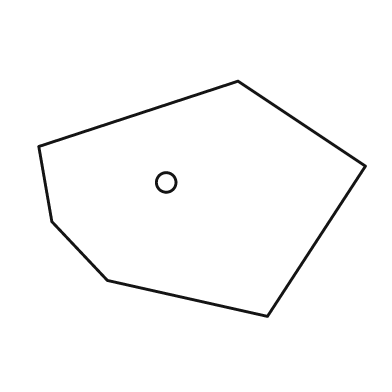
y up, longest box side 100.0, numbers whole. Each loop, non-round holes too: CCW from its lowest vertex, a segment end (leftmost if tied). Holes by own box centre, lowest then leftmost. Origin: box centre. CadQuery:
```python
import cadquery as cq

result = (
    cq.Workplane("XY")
    .moveTo(20.0, -36.0)
    .lineTo(50.0, 10.0)
    .lineTo(11.0, 36.0)
    .lineTo(-50.0, 16.0)
    .lineTo(-46.0, -7.0)
    .lineTo(-29.0, -25.0)
    .close()
    .moveTo(-11.0, 5.0)
    .circle(3.0)
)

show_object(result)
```